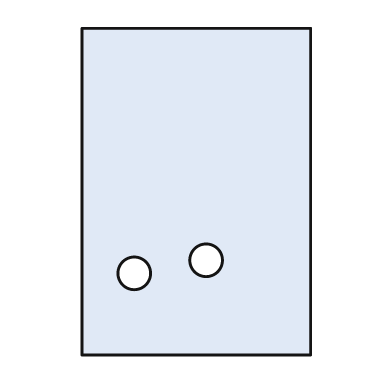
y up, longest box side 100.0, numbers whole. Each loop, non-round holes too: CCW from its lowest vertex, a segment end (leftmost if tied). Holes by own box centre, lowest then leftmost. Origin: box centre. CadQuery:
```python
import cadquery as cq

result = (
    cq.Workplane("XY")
    .moveTo(-35.0, -50.0)
    .lineTo(35.0, -50.0)
    .lineTo(35.0, 50.0)
    .lineTo(-35.0, 50.0)
    .close()
    .moveTo(-19.0, -25.0)
    .circle(5.0)
    .moveTo(3.0, -21.0)
    .circle(5.0)
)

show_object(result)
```